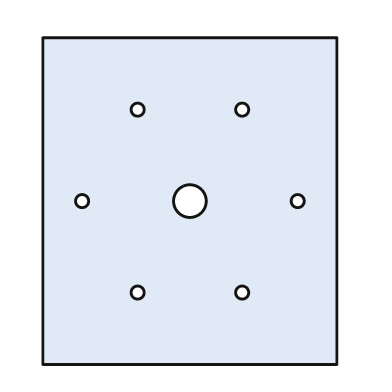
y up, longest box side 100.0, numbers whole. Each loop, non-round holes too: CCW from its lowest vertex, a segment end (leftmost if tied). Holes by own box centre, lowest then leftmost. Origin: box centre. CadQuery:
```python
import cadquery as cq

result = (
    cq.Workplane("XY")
    .moveTo(-45.0, -50.0)
    .lineTo(45.0, -50.0)
    .lineTo(45.0, 50.0)
    .lineTo(-45.0, 50.0)
    .close()
    .moveTo(-16.0, -28.0)
    .circle(2.0)
    .moveTo(16.0, -28.0)
    .circle(2.0)
    .moveTo(-33.0, 0.0)
    .circle(2.0)
    .moveTo(0.0, 0.0)
    .circle(5.0)
    .moveTo(33.0, 0.0)
    .circle(2.0)
    .moveTo(-16.0, 28.0)
    .circle(2.0)
    .moveTo(16.0, 28.0)
    .circle(2.0)
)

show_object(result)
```